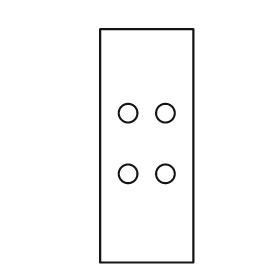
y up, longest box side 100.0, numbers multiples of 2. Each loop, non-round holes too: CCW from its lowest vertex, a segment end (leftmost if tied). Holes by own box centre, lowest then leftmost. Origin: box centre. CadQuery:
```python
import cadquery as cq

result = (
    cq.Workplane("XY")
    .moveTo(-20.0, -50.0)
    .lineTo(20.0, -50.0)
    .lineTo(20.0, 50.0)
    .lineTo(-20.0, 50.0)
    .close()
    .moveTo(-8.0, -12.0)
    .circle(4.0)
    .moveTo(8.0, -12.0)
    .circle(4.0)
    .moveTo(-8.0, 14.0)
    .circle(4.0)
    .moveTo(8.0, 14.0)
    .circle(4.0)
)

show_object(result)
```